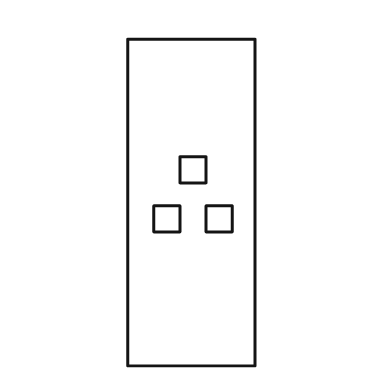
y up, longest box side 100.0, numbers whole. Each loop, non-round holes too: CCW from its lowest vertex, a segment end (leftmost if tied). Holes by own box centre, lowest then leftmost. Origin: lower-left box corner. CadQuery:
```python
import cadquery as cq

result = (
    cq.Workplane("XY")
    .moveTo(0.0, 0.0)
    .lineTo(39.0, 0.0)
    .lineTo(39.0, 100.0)
    .lineTo(0.0, 100.0)
    .close()
    .moveTo(8.0, 41.0)
    .lineTo(16.0, 41.0)
    .lineTo(16.0, 49.0)
    .lineTo(8.0, 49.0)
    .close()
    .moveTo(24.0, 41.0)
    .lineTo(32.0, 41.0)
    .lineTo(32.0, 49.0)
    .lineTo(24.0, 49.0)
    .close()
    .moveTo(16.0, 56.0)
    .lineTo(24.0, 56.0)
    .lineTo(24.0, 64.0)
    .lineTo(16.0, 64.0)
    .close()
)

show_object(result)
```